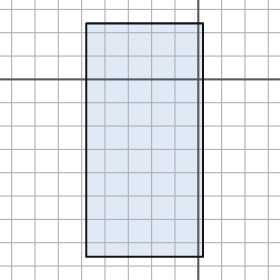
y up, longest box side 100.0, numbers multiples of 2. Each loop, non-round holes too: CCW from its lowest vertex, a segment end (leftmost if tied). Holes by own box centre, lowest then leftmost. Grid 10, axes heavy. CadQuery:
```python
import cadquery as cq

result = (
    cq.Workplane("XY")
    .moveTo(-48.0, -76.0)
    .lineTo(2.0, -76.0)
    .lineTo(2.0, 24.0)
    .lineTo(-48.0, 24.0)
    .close()
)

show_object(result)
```